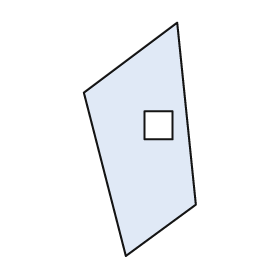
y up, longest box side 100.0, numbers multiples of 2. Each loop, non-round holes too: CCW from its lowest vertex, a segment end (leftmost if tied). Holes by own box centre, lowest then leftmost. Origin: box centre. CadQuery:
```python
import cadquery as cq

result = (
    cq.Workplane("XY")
    .moveTo(-6.0, -50.0)
    .lineTo(24.0, -28.0)
    .lineTo(16.0, 50.0)
    .lineTo(-24.0, 20.0)
    .close()
    .moveTo(2.0, 0.0)
    .lineTo(14.0, 0.0)
    .lineTo(14.0, 12.0)
    .lineTo(2.0, 12.0)
    .close()
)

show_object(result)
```